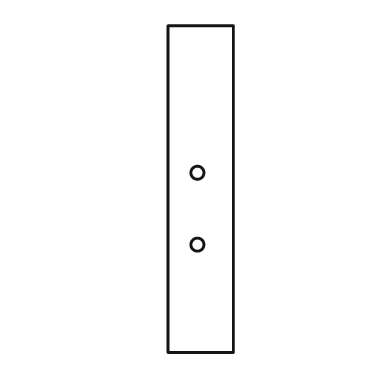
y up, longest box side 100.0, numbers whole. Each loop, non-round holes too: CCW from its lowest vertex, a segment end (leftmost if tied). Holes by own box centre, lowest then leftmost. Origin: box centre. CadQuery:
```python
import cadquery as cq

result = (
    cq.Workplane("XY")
    .moveTo(-10.0, -50.0)
    .lineTo(10.0, -50.0)
    .lineTo(10.0, 50.0)
    .lineTo(-10.0, 50.0)
    .close()
    .moveTo(-1.0, -17.0)
    .circle(2.0)
    .moveTo(-1.0, 5.0)
    .circle(2.0)
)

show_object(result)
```